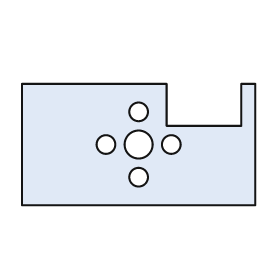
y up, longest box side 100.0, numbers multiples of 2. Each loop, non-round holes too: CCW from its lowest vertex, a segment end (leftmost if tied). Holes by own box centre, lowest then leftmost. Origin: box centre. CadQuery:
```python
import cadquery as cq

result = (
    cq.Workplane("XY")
    .moveTo(-50.0, -26.0)
    .lineTo(50.0, -26.0)
    .lineTo(50.0, 26.0)
    .lineTo(44.0, 26.0)
    .lineTo(44.0, 8.0)
    .lineTo(12.0, 8.0)
    .lineTo(12.0, 26.0)
    .lineTo(-50.0, 26.0)
    .close()
    .moveTo(0.0, -14.0)
    .circle(4.0)
    .moveTo(-14.0, 0.0)
    .circle(4.0)
    .moveTo(0.0, 0.0)
    .circle(6.0)
    .moveTo(14.0, 0.0)
    .circle(4.0)
    .moveTo(0.0, 14.0)
    .circle(4.0)
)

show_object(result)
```